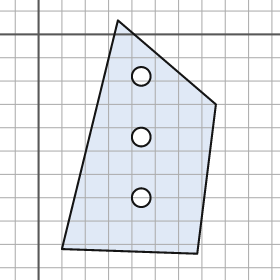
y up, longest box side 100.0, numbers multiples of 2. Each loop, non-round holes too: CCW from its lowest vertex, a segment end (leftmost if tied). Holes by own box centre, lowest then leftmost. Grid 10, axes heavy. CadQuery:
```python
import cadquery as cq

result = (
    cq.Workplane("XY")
    .moveTo(68.0, -94.0)
    .lineTo(76.0, -30.0)
    .lineTo(34.0, 6.0)
    .lineTo(10.0, -92.0)
    .close()
    .moveTo(44.0, -70.0)
    .circle(4.0)
    .moveTo(44.0, -44.0)
    .circle(4.0)
    .moveTo(44.0, -18.0)
    .circle(4.0)
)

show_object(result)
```